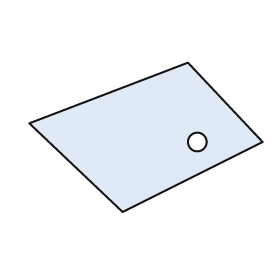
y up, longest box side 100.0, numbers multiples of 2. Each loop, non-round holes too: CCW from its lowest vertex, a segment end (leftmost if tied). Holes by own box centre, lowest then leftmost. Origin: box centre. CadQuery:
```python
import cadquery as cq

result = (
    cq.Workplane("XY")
    .moveTo(-10.0, -32.0)
    .lineTo(50.0, -2.0)
    .lineTo(18.0, 32.0)
    .lineTo(-50.0, 6.0)
    .close()
    .moveTo(22.0, -2.0)
    .circle(4.0)
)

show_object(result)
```